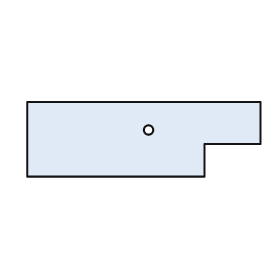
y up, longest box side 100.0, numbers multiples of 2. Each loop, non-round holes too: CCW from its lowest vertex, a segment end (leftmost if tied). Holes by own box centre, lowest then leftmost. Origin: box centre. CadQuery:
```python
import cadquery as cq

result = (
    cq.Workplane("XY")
    .moveTo(-50.0, -16.0)
    .lineTo(26.0, -16.0)
    .lineTo(26.0, -2.0)
    .lineTo(50.0, -2.0)
    .lineTo(50.0, 16.0)
    .lineTo(-50.0, 16.0)
    .close()
    .moveTo(2.0, 4.0)
    .circle(2.0)
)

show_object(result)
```